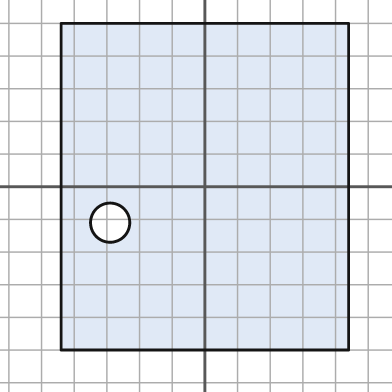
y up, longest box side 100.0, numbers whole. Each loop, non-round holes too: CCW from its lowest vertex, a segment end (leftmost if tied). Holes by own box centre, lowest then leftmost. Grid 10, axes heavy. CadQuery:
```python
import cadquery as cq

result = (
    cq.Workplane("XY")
    .moveTo(-44.0, -50.0)
    .lineTo(44.0, -50.0)
    .lineTo(44.0, 50.0)
    .lineTo(-44.0, 50.0)
    .close()
    .moveTo(-29.0, -11.0)
    .circle(6.0)
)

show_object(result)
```